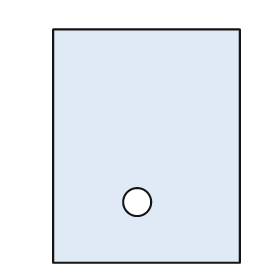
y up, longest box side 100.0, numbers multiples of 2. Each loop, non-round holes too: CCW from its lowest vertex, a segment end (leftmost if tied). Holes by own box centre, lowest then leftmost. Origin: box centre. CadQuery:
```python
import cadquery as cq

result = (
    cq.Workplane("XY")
    .moveTo(-40.0, -50.0)
    .lineTo(40.0, -50.0)
    .lineTo(40.0, 50.0)
    .lineTo(-40.0, 50.0)
    .close()
    .moveTo(-4.0, -24.0)
    .circle(6.0)
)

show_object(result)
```